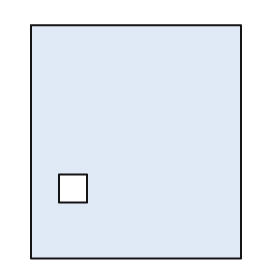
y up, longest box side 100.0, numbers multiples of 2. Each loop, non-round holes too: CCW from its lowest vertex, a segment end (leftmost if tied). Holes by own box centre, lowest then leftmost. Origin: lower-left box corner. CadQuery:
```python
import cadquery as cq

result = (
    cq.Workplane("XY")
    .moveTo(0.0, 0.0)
    .lineTo(90.0, 0.0)
    .lineTo(90.0, 100.0)
    .lineTo(0.0, 100.0)
    .close()
    .moveTo(12.0, 24.0)
    .lineTo(24.0, 24.0)
    .lineTo(24.0, 36.0)
    .lineTo(12.0, 36.0)
    .close()
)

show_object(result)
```